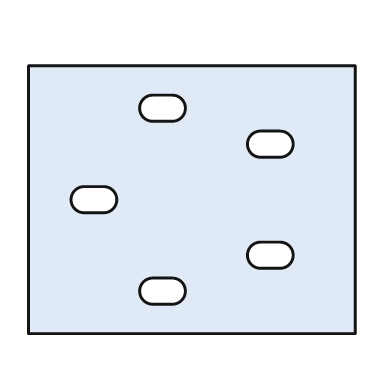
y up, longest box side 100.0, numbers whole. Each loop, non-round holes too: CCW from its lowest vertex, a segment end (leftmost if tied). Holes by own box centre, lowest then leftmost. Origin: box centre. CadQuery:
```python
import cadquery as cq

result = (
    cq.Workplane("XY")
    .moveTo(-50.0, -41.0)
    .lineTo(50.0, -41.0)
    .lineTo(50.0, 41.0)
    .lineTo(-50.0, 41.0)
    .close()
    .moveTo(-12.0, -32.0)
    .lineTo(-6.0, -32.0)
    .threePointArc((-2.0, -28.0), (-6.0, -24.0))
    .lineTo(-12.0, -24.0)
    .threePointArc((-16.0, -28.0), (-12.0, -32.0))
    .close()
    .moveTo(21.0, -21.0)
    .lineTo(27.0, -21.0)
    .threePointArc((31.0, -17.0), (27.0, -13.0))
    .lineTo(21.0, -13.0)
    .threePointArc((17.0, -17.0), (21.0, -21.0))
    .close()
    .moveTo(-33.0, -4.0)
    .lineTo(-27.0, -4.0)
    .threePointArc((-23.0, 0.0), (-27.0, 4.0))
    .lineTo(-33.0, 4.0)
    .threePointArc((-37.0, 0.0), (-33.0, -4.0))
    .close()
    .moveTo(21.0, 13.0)
    .lineTo(27.0, 13.0)
    .threePointArc((31.0, 17.0), (27.0, 21.0))
    .lineTo(21.0, 21.0)
    .threePointArc((17.0, 17.0), (21.0, 13.0))
    .close()
    .moveTo(-12.0, 24.0)
    .lineTo(-6.0, 24.0)
    .threePointArc((-2.0, 28.0), (-6.0, 32.0))
    .lineTo(-12.0, 32.0)
    .threePointArc((-16.0, 28.0), (-12.0, 24.0))
    .close()
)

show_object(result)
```